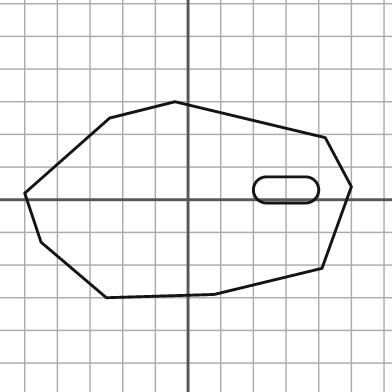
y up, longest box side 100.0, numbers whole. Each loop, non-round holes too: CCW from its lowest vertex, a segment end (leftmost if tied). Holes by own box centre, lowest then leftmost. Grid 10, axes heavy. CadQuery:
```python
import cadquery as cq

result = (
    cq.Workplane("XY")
    .moveTo(-25.0, -30.0)
    .lineTo(8.0, -29.0)
    .lineTo(41.0, -21.0)
    .lineTo(50.0, 4.0)
    .lineTo(42.0, 19.0)
    .lineTo(-4.0, 30.0)
    .lineTo(-24.0, 25.0)
    .lineTo(-50.0, 2.0)
    .lineTo(-45.0, -13.0)
    .close()
    .moveTo(24.0, -1.0)
    .lineTo(36.0, -1.0)
    .threePointArc((40.0, 3.0), (36.0, 7.0))
    .lineTo(24.0, 7.0)
    .threePointArc((20.0, 3.0), (24.0, -1.0))
    .close()
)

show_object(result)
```